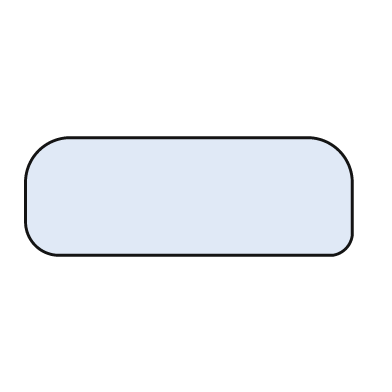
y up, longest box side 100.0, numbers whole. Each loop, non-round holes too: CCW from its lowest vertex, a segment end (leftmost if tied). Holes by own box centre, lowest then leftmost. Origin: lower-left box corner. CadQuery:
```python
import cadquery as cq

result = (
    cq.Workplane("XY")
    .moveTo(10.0, 0.0)
    .lineTo(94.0, 0.0)
    .threePointArc((98.0, 2.0), (100.0, 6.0))
    .lineTo(100.0, 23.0)
    .threePointArc((96.0, 32.0), (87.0, 36.0))
    .lineTo(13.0, 36.0)
    .threePointArc((4.0, 32.0), (0.0, 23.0))
    .lineTo(0.0, 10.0)
    .threePointArc((3.0, 3.0), (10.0, 0.0))
    .close()
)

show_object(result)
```